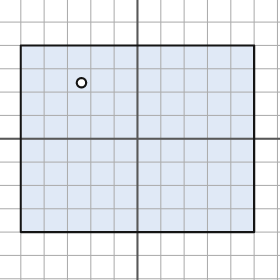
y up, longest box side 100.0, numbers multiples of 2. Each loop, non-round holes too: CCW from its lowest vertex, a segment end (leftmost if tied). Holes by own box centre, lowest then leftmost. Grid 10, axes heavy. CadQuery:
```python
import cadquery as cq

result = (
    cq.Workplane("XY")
    .moveTo(-50.0, -40.0)
    .lineTo(50.0, -40.0)
    .lineTo(50.0, 40.0)
    .lineTo(-50.0, 40.0)
    .close()
    .moveTo(-24.0, 24.0)
    .circle(2.0)
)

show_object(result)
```